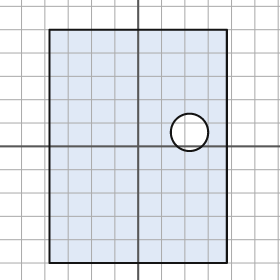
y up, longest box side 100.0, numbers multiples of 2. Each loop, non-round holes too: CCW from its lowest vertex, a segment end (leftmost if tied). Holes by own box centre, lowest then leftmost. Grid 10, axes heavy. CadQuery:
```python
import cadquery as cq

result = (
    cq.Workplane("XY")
    .moveTo(-38.0, -50.0)
    .lineTo(38.0, -50.0)
    .lineTo(38.0, 50.0)
    .lineTo(-38.0, 50.0)
    .close()
    .moveTo(22.0, 6.0)
    .circle(8.0)
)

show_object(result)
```